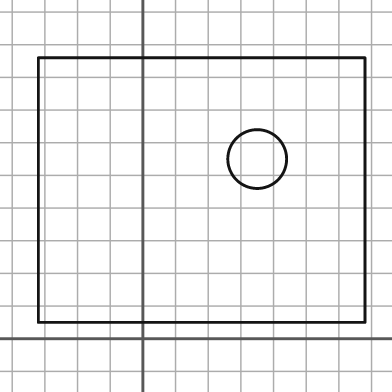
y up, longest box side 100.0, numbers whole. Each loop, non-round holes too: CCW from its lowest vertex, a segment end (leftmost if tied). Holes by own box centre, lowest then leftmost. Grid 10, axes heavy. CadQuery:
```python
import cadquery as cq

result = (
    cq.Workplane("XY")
    .moveTo(-32.0, 5.0)
    .lineTo(68.0, 5.0)
    .lineTo(68.0, 86.0)
    .lineTo(-32.0, 86.0)
    .close()
    .moveTo(35.0, 55.0)
    .circle(9.0)
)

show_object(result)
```